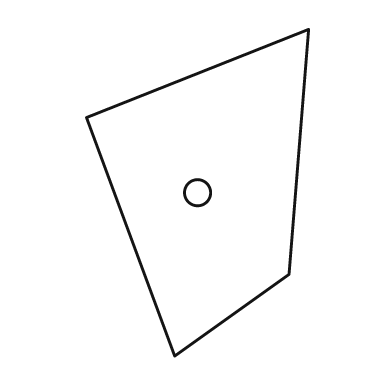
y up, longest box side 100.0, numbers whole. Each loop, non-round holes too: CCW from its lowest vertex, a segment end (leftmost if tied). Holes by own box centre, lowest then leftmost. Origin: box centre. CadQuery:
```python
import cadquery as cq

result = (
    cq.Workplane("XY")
    .moveTo(-7.0, -50.0)
    .lineTo(28.0, -25.0)
    .lineTo(34.0, 50.0)
    .lineTo(-34.0, 23.0)
    .close()
    .moveTo(0.0, 0.0)
    .circle(4.0)
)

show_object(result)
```